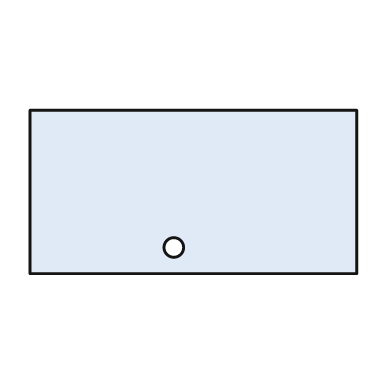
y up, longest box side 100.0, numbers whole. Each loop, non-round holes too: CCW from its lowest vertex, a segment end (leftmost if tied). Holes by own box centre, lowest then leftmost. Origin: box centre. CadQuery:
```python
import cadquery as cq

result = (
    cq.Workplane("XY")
    .moveTo(-50.0, -25.0)
    .lineTo(50.0, -25.0)
    .lineTo(50.0, 25.0)
    .lineTo(-50.0, 25.0)
    .close()
    .moveTo(-6.0, -17.0)
    .circle(3.0)
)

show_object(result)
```